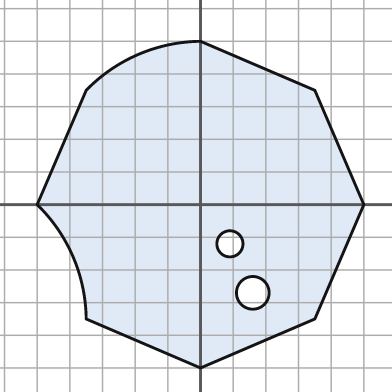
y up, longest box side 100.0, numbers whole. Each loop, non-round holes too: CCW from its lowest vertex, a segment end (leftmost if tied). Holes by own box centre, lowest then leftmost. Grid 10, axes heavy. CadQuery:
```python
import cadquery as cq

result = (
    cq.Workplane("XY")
    .moveTo(0.0, -50.0)
    .lineTo(35.0, -35.0)
    .lineTo(50.0, 0.0)
    .lineTo(35.0, 35.0)
    .lineTo(0.0, 50.0)
    .threePointArc((-19.0, 46.0), (-35.0, 35.0))
    .lineTo(-50.0, 0.0)
    .threePointArc((-39.0, -16.0), (-35.0, -35.0))
    .close()
    .moveTo(16.0, -27.0)
    .circle(5.0)
    .moveTo(9.0, -12.0)
    .circle(4.0)
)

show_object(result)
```